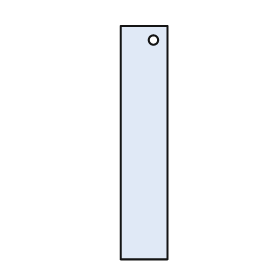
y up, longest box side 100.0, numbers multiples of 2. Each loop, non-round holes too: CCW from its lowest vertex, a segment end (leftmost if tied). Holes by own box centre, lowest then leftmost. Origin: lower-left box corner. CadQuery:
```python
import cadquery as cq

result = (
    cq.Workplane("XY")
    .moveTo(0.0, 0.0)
    .lineTo(20.0, 0.0)
    .lineTo(20.0, 100.0)
    .lineTo(0.0, 100.0)
    .close()
    .moveTo(14.0, 94.0)
    .circle(2.0)
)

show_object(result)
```